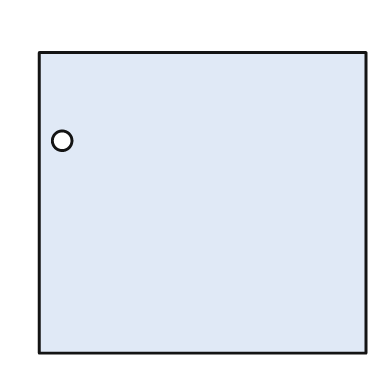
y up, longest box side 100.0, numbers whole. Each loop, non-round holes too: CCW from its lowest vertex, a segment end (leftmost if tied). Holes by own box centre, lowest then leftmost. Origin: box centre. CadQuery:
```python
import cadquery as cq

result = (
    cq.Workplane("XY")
    .moveTo(-50.0, -46.0)
    .lineTo(50.0, -46.0)
    .lineTo(50.0, 46.0)
    .lineTo(-50.0, 46.0)
    .close()
    .moveTo(-43.0, 19.0)
    .circle(3.0)
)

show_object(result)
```